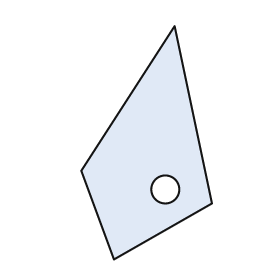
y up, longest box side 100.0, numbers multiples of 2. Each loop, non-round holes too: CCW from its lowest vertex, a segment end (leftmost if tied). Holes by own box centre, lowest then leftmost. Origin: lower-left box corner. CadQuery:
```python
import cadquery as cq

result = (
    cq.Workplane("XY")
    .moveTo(14.0, 0.0)
    .lineTo(56.0, 24.0)
    .lineTo(40.0, 100.0)
    .lineTo(0.0, 38.0)
    .close()
    .moveTo(36.0, 30.0)
    .circle(6.0)
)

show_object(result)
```